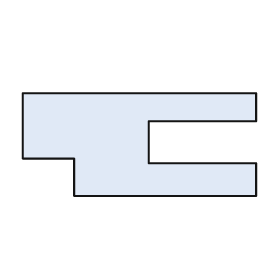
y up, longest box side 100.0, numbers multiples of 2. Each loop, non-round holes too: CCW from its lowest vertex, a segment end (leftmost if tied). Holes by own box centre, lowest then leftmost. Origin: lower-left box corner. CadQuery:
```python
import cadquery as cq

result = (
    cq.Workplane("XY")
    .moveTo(22.0, 0.0)
    .lineTo(100.0, 0.0)
    .lineTo(100.0, 14.0)
    .lineTo(54.0, 14.0)
    .lineTo(54.0, 32.0)
    .lineTo(100.0, 32.0)
    .lineTo(100.0, 44.0)
    .lineTo(0.0, 44.0)
    .lineTo(0.0, 16.0)
    .lineTo(22.0, 16.0)
    .close()
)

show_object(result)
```